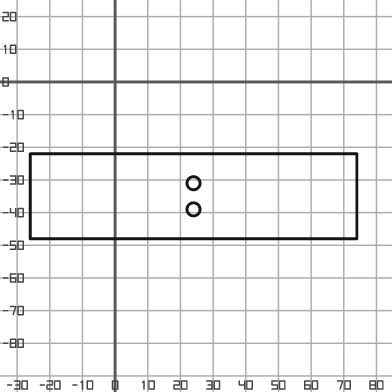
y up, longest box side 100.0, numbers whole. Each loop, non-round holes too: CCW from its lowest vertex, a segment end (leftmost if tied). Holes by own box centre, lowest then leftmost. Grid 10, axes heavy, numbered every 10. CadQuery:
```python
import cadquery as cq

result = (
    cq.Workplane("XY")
    .moveTo(-26.0, -48.0)
    .lineTo(74.0, -48.0)
    .lineTo(74.0, -22.0)
    .lineTo(-26.0, -22.0)
    .close()
    .moveTo(24.0, -39.0)
    .circle(2.0)
    .moveTo(24.0, -31.0)
    .circle(2.0)
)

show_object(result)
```